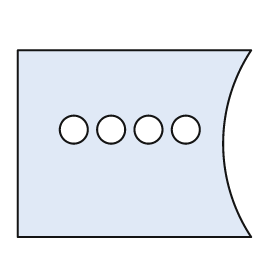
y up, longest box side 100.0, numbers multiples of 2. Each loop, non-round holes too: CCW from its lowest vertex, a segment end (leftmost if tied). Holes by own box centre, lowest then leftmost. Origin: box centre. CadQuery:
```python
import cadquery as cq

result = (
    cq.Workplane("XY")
    .moveTo(-50.0, -40.0)
    .lineTo(50.0, -40.0)
    .threePointArc((38.0, 0.0), (50.0, 40.0))
    .lineTo(-50.0, 40.0)
    .close()
    .moveTo(-26.0, 6.0)
    .circle(6.0)
    .moveTo(-10.0, 6.0)
    .circle(6.0)
    .moveTo(6.0, 6.0)
    .circle(6.0)
    .moveTo(22.0, 6.0)
    .circle(6.0)
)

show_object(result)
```